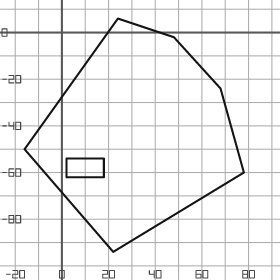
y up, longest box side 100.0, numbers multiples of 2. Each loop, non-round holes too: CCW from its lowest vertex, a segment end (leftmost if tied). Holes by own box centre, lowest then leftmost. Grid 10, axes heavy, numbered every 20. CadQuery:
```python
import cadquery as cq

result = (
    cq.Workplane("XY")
    .moveTo(22.0, -94.0)
    .lineTo(78.0, -60.0)
    .lineTo(68.0, -24.0)
    .lineTo(48.0, -2.0)
    .lineTo(24.0, 6.0)
    .lineTo(-16.0, -50.0)
    .close()
    .moveTo(2.0, -62.0)
    .lineTo(18.0, -62.0)
    .lineTo(18.0, -54.0)
    .lineTo(2.0, -54.0)
    .close()
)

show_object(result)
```